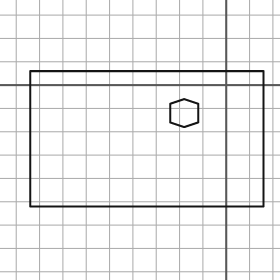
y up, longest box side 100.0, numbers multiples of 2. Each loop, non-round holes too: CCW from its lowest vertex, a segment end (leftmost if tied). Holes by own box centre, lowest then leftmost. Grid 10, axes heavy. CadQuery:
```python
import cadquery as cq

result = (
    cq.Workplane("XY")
    .moveTo(-84.0, -52.0)
    .lineTo(16.0, -52.0)
    .lineTo(16.0, 6.0)
    .lineTo(-84.0, 6.0)
    .close()
    .moveTo(-18.0, -18.0)
    .lineTo(-12.0, -16.0)
    .lineTo(-12.0, -8.0)
    .lineTo(-18.0, -6.0)
    .lineTo(-24.0, -8.0)
    .lineTo(-24.0, -16.0)
    .close()
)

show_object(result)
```